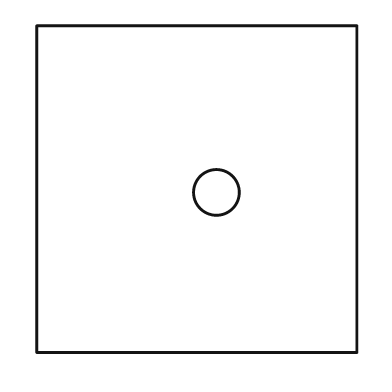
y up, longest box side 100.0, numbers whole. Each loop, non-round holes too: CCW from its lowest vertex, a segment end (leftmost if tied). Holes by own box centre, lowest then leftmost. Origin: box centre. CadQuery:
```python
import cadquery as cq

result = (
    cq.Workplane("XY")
    .moveTo(-49.0, -50.0)
    .lineTo(49.0, -50.0)
    .lineTo(49.0, 50.0)
    .lineTo(-49.0, 50.0)
    .close()
    .moveTo(6.0, -1.0)
    .circle(7.0)
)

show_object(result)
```